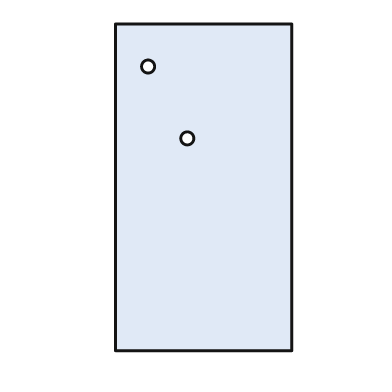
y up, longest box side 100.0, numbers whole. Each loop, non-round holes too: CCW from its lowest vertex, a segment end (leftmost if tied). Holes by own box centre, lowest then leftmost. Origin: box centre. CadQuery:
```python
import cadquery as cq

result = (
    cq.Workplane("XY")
    .moveTo(-27.0, -50.0)
    .lineTo(27.0, -50.0)
    .lineTo(27.0, 50.0)
    .lineTo(-27.0, 50.0)
    .close()
    .moveTo(-5.0, 15.0)
    .circle(2.0)
    .moveTo(-17.0, 37.0)
    .circle(2.0)
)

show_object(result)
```